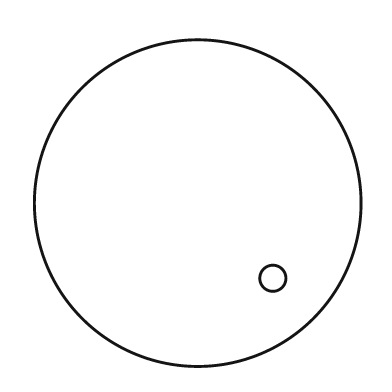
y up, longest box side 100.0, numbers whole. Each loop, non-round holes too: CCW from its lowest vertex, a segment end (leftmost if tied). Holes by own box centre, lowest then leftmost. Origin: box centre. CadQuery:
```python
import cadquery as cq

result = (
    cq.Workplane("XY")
    .moveTo(0.0, 0.0)
    .circle(50.0)
    .moveTo(23.0, -23.0)
    .circle(4.0)
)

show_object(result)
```